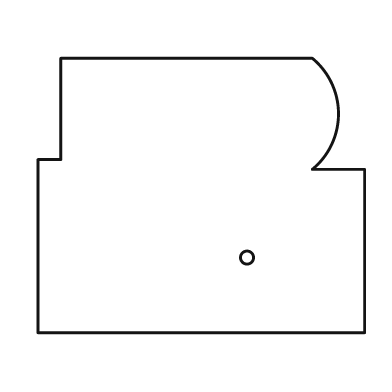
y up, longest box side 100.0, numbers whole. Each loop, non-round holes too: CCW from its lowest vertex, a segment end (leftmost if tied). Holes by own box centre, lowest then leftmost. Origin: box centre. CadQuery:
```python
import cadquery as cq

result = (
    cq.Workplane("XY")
    .moveTo(-50.0, -42.0)
    .lineTo(50.0, -42.0)
    .lineTo(50.0, 8.0)
    .lineTo(34.0, 8.0)
    .threePointArc((42.0, 25.0), (34.0, 42.0))
    .lineTo(-43.0, 42.0)
    .lineTo(-43.0, 11.0)
    .lineTo(-50.0, 11.0)
    .close()
    .moveTo(14.0, -19.0)
    .circle(2.0)
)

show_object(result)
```